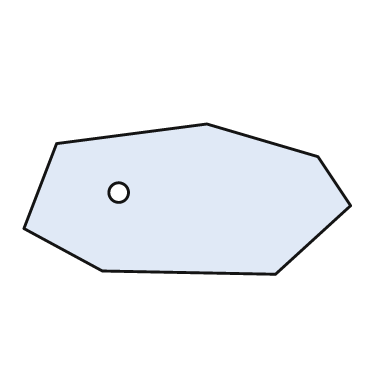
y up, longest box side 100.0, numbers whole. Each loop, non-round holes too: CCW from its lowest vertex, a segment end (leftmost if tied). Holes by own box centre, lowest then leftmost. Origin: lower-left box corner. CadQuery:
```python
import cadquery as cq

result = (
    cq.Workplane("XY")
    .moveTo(77.0, 0.0)
    .lineTo(100.0, 21.0)
    .lineTo(90.0, 36.0)
    .lineTo(56.0, 46.0)
    .lineTo(10.0, 40.0)
    .lineTo(0.0, 14.0)
    .lineTo(24.0, 1.0)
    .close()
    .moveTo(29.0, 25.0)
    .circle(3.0)
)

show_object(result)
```